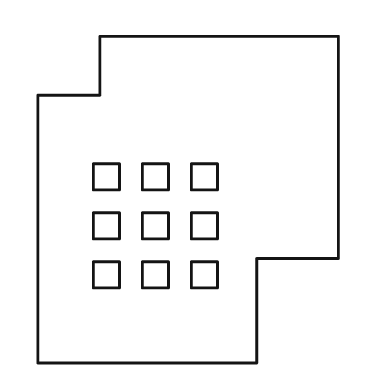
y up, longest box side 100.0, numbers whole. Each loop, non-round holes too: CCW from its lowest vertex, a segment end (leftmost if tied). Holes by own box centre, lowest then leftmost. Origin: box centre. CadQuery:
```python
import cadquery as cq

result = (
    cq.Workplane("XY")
    .moveTo(-46.0, -50.0)
    .lineTo(21.0, -50.0)
    .lineTo(21.0, -18.0)
    .lineTo(46.0, -18.0)
    .lineTo(46.0, 50.0)
    .lineTo(-27.0, 50.0)
    .lineTo(-27.0, 32.0)
    .lineTo(-46.0, 32.0)
    .close()
    .moveTo(-29.0, -27.0)
    .lineTo(-21.0, -27.0)
    .lineTo(-21.0, -19.0)
    .lineTo(-29.0, -19.0)
    .close()
    .moveTo(-14.0, -27.0)
    .lineTo(-6.0, -27.0)
    .lineTo(-6.0, -19.0)
    .lineTo(-14.0, -19.0)
    .close()
    .moveTo(1.0, -27.0)
    .lineTo(9.0, -27.0)
    .lineTo(9.0, -19.0)
    .lineTo(1.0, -19.0)
    .close()
    .moveTo(-29.0, -12.0)
    .lineTo(-21.0, -12.0)
    .lineTo(-21.0, -4.0)
    .lineTo(-29.0, -4.0)
    .close()
    .moveTo(-14.0, -12.0)
    .lineTo(-6.0, -12.0)
    .lineTo(-6.0, -4.0)
    .lineTo(-14.0, -4.0)
    .close()
    .moveTo(1.0, -12.0)
    .lineTo(9.0, -12.0)
    .lineTo(9.0, -4.0)
    .lineTo(1.0, -4.0)
    .close()
    .moveTo(-29.0, 3.0)
    .lineTo(-21.0, 3.0)
    .lineTo(-21.0, 11.0)
    .lineTo(-29.0, 11.0)
    .close()
    .moveTo(-14.0, 3.0)
    .lineTo(-6.0, 3.0)
    .lineTo(-6.0, 11.0)
    .lineTo(-14.0, 11.0)
    .close()
    .moveTo(1.0, 3.0)
    .lineTo(9.0, 3.0)
    .lineTo(9.0, 11.0)
    .lineTo(1.0, 11.0)
    .close()
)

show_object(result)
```